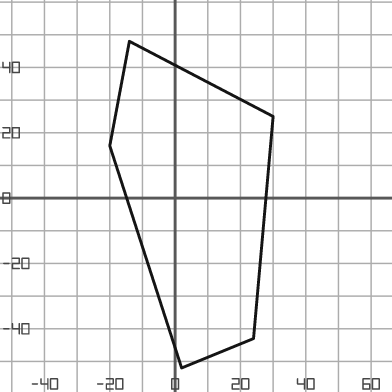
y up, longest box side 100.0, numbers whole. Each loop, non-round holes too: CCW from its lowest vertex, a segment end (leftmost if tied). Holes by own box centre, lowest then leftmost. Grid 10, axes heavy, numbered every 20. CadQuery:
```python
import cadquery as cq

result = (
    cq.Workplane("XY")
    .moveTo(2.0, -52.0)
    .lineTo(24.0, -43.0)
    .lineTo(30.0, 25.0)
    .lineTo(-14.0, 48.0)
    .lineTo(-20.0, 16.0)
    .close()
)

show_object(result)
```